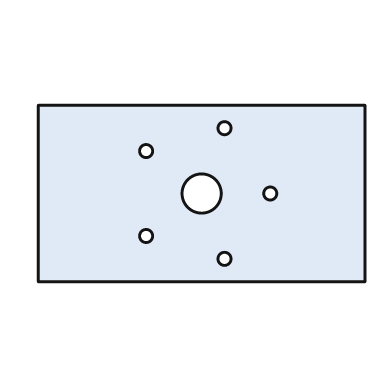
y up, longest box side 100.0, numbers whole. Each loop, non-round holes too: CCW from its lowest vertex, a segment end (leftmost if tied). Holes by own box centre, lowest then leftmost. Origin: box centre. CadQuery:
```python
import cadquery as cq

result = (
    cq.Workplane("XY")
    .moveTo(-50.0, -27.0)
    .lineTo(50.0, -27.0)
    .lineTo(50.0, 27.0)
    .lineTo(-50.0, 27.0)
    .close()
    .moveTo(7.0, -20.0)
    .circle(2.0)
    .moveTo(-17.0, -13.0)
    .circle(2.0)
    .moveTo(0.0, 0.0)
    .circle(6.0)
    .moveTo(21.0, 0.0)
    .circle(2.0)
    .moveTo(-17.0, 13.0)
    .circle(2.0)
    .moveTo(7.0, 20.0)
    .circle(2.0)
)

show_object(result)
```